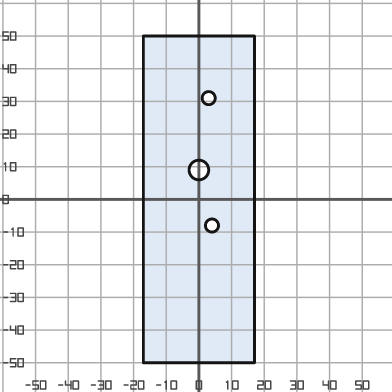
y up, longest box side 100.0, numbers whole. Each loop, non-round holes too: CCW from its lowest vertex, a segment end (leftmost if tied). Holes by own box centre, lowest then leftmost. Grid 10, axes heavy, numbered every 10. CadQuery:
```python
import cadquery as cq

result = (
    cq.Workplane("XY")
    .moveTo(-17.0, -50.0)
    .lineTo(17.0, -50.0)
    .lineTo(17.0, 50.0)
    .lineTo(-17.0, 50.0)
    .close()
    .moveTo(4.0, -8.0)
    .circle(2.0)
    .moveTo(0.0, 9.0)
    .circle(3.0)
    .moveTo(3.0, 31.0)
    .circle(2.0)
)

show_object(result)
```